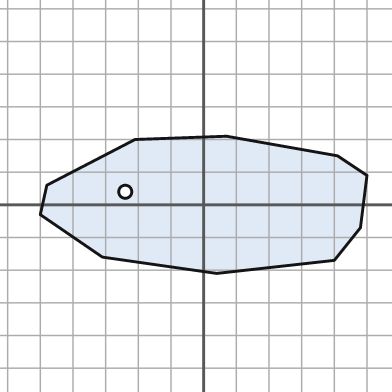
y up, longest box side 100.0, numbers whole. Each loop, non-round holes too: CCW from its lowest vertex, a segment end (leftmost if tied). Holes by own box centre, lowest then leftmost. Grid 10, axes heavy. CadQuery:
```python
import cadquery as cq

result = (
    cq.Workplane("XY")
    .moveTo(4.0, -21.0)
    .lineTo(40.0, -17.0)
    .lineTo(48.0, -7.0)
    .lineTo(50.0, 9.0)
    .lineTo(41.0, 15.0)
    .lineTo(7.0, 21.0)
    .lineTo(-21.0, 20.0)
    .lineTo(-48.0, 6.0)
    .lineTo(-50.0, -3.0)
    .lineTo(-31.0, -16.0)
    .close()
    .moveTo(-24.0, 4.0)
    .circle(2.0)
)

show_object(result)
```